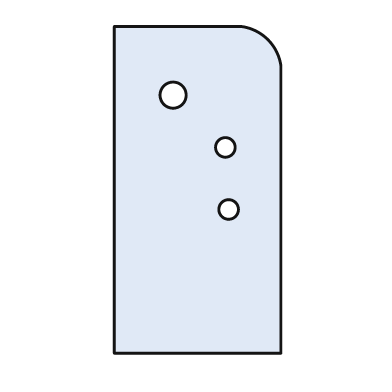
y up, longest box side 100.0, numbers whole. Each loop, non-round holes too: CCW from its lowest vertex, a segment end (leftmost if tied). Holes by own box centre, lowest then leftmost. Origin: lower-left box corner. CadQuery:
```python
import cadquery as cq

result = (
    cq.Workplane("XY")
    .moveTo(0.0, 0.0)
    .lineTo(51.0, 0.0)
    .lineTo(51.0, 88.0)
    .threePointArc((47.0, 96.0), (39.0, 100.0))
    .lineTo(0.0, 100.0)
    .close()
    .moveTo(35.0, 44.0)
    .circle(3.0)
    .moveTo(34.0, 63.0)
    .circle(3.0)
    .moveTo(18.0, 79.0)
    .circle(4.0)
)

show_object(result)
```